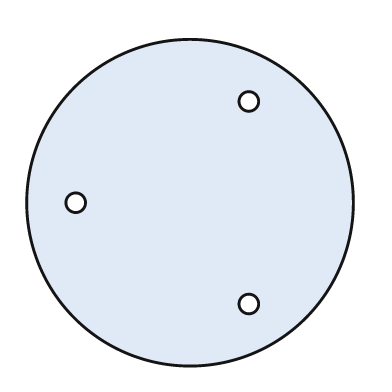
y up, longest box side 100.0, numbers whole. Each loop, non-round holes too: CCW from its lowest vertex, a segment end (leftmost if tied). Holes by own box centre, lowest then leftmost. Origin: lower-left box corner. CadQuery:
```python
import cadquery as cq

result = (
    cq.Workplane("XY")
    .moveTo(50.0, 50.0)
    .circle(50.0)
    .moveTo(68.0, 19.0)
    .circle(3.0)
    .moveTo(15.0, 50.0)
    .circle(3.0)
    .moveTo(68.0, 81.0)
    .circle(3.0)
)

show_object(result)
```